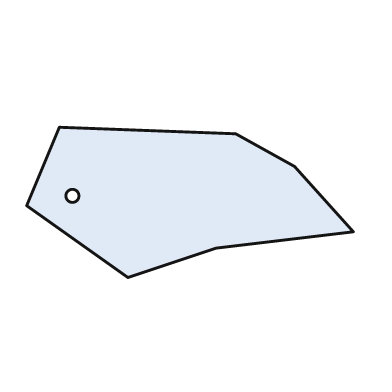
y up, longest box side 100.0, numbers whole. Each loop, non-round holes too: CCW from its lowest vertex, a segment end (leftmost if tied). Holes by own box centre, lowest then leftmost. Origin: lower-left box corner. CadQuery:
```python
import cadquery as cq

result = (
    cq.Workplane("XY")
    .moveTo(31.0, 0.0)
    .lineTo(58.0, 9.0)
    .lineTo(100.0, 14.0)
    .lineTo(82.0, 34.0)
    .lineTo(64.0, 44.0)
    .lineTo(10.0, 46.0)
    .lineTo(0.0, 22.0)
    .close()
    .moveTo(14.0, 25.0)
    .circle(2.0)
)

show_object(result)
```